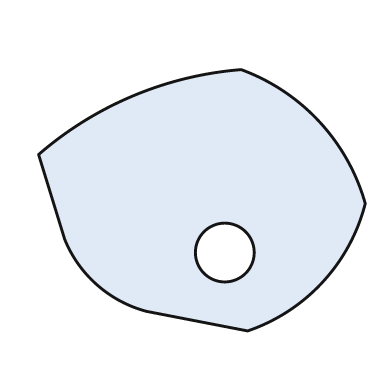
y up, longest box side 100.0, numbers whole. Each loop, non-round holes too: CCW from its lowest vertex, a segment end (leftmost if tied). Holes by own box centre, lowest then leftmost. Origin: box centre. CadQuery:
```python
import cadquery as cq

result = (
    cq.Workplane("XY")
    .moveTo(14.0, -40.0)
    .threePointArc((37.0, -25.0), (50.0, -1.0))
    .threePointArc((36.0, 24.0), (12.0, 40.0))
    .threePointArc((-21.0, 32.0), (-50.0, 14.0))
    .lineTo(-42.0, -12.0)
    .threePointArc((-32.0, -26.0), (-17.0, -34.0))
    .close()
    .moveTo(7.0, -16.0)
    .circle(9.0)
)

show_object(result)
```